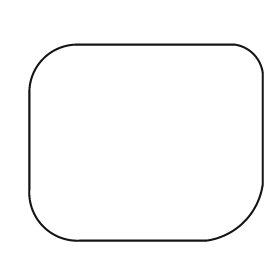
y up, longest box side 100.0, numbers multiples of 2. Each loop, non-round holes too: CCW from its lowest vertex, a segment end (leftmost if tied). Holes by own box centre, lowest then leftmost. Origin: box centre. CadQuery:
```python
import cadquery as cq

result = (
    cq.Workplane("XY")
    .moveTo(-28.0, -42.0)
    .lineTo(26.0, -42.0)
    .threePointArc((42.0, -34.0), (50.0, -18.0))
    .lineTo(50.0, 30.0)
    .threePointArc((46.0, 38.0), (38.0, 42.0))
    .lineTo(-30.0, 42.0)
    .threePointArc((-44.0, 36.0), (-50.0, 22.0))
    .lineTo(-50.0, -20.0)
    .threePointArc((-44.0, -36.0), (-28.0, -42.0))
    .close()
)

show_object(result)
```